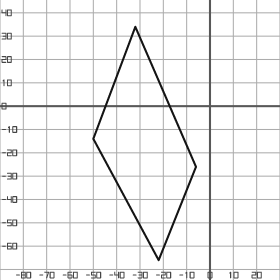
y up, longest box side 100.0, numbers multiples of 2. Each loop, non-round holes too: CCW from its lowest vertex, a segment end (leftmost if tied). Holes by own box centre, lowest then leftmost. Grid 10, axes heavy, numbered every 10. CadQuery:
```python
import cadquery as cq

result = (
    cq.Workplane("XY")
    .moveTo(-22.0, -66.0)
    .lineTo(-6.0, -26.0)
    .lineTo(-32.0, 34.0)
    .lineTo(-50.0, -14.0)
    .close()
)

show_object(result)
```